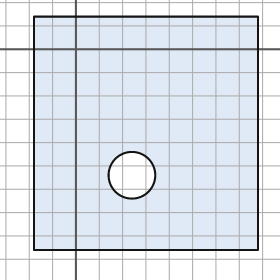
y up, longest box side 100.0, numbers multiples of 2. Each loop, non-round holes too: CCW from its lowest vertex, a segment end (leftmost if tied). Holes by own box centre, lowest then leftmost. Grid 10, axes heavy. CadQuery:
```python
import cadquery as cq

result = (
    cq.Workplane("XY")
    .moveTo(-18.0, -86.0)
    .lineTo(78.0, -86.0)
    .lineTo(78.0, 14.0)
    .lineTo(-18.0, 14.0)
    .close()
    .moveTo(24.0, -54.0)
    .circle(10.0)
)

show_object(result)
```